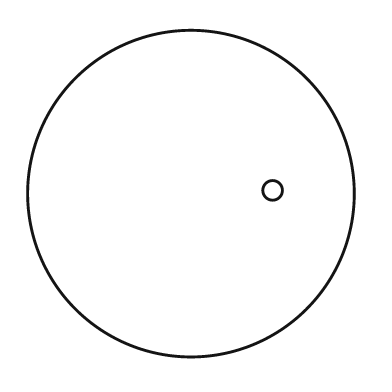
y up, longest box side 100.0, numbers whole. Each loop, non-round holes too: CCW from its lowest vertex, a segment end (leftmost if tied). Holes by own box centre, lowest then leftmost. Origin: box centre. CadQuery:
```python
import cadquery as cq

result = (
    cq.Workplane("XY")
    .moveTo(0.0, 0.0)
    .circle(50.0)
    .moveTo(25.0, 1.0)
    .circle(3.0)
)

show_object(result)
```